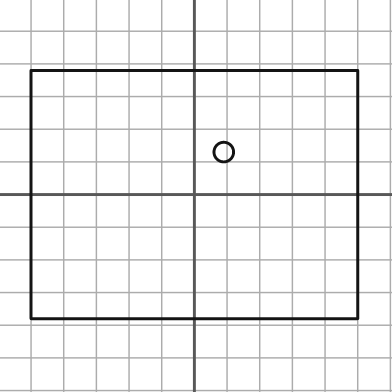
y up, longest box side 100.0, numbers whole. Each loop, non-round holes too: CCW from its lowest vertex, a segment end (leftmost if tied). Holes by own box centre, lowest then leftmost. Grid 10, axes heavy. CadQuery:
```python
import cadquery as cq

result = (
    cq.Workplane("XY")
    .moveTo(-50.0, -38.0)
    .lineTo(50.0, -38.0)
    .lineTo(50.0, 38.0)
    .lineTo(-50.0, 38.0)
    .close()
    .moveTo(9.0, 13.0)
    .circle(3.0)
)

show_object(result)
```